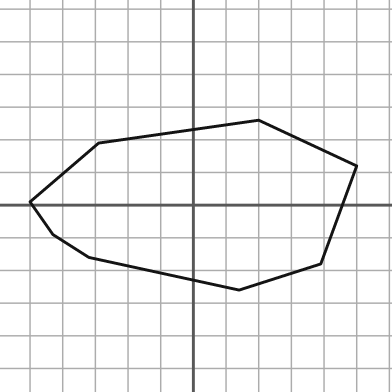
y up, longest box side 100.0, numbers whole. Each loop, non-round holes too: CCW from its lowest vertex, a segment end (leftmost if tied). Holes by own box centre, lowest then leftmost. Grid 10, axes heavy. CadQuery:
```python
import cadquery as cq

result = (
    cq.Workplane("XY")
    .moveTo(14.0, -26.0)
    .lineTo(39.0, -18.0)
    .lineTo(50.0, 12.0)
    .lineTo(20.0, 26.0)
    .lineTo(-29.0, 19.0)
    .lineTo(-50.0, 1.0)
    .lineTo(-43.0, -9.0)
    .lineTo(-32.0, -16.0)
    .close()
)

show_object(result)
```